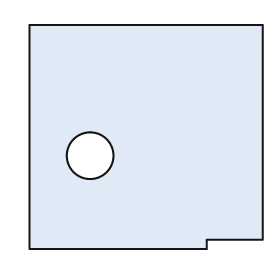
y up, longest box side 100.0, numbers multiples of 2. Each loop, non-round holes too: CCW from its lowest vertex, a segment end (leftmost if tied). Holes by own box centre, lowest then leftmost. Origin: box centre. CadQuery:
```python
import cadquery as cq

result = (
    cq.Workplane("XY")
    .moveTo(-50.0, -48.0)
    .lineTo(26.0, -48.0)
    .lineTo(26.0, -44.0)
    .lineTo(50.0, -44.0)
    .lineTo(50.0, 48.0)
    .lineTo(-50.0, 48.0)
    .close()
    .moveTo(-24.0, -8.0)
    .circle(10.0)
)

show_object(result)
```